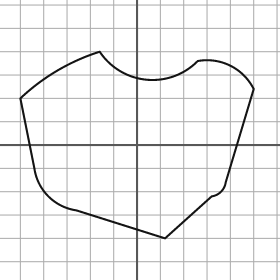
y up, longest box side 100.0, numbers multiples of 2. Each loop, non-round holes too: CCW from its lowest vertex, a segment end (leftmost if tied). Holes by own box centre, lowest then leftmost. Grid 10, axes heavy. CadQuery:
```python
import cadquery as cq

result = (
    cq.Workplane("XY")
    .moveTo(12.0, -40.0)
    .lineTo(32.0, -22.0)
    .threePointArc((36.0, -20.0), (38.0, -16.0))
    .lineTo(50.0, 24.0)
    .threePointArc((40.0, 34.0), (26.0, 36.0))
    .threePointArc((4.0, 28.0), (-16.0, 40.0))
    .threePointArc((-34.0, 32.0), (-50.0, 20.0))
    .lineTo(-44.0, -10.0)
    .threePointArc((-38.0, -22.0), (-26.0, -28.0))
    .close()
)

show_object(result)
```